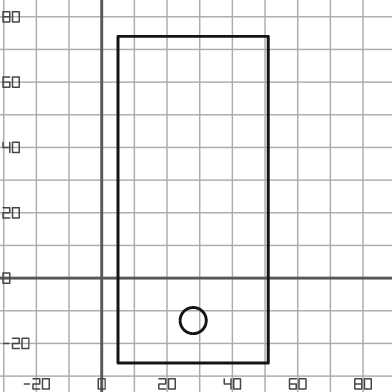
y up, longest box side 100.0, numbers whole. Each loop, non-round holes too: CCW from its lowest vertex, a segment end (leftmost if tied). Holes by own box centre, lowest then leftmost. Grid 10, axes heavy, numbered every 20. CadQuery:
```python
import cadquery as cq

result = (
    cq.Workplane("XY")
    .moveTo(5.0, -26.0)
    .lineTo(51.0, -26.0)
    .lineTo(51.0, 74.0)
    .lineTo(5.0, 74.0)
    .close()
    .moveTo(28.0, -13.0)
    .circle(4.0)
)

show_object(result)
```